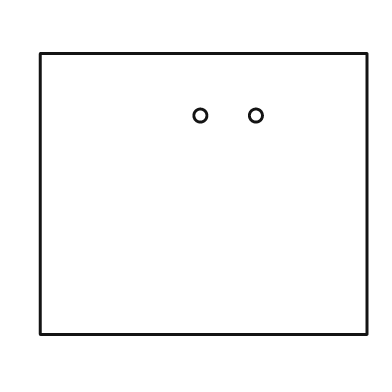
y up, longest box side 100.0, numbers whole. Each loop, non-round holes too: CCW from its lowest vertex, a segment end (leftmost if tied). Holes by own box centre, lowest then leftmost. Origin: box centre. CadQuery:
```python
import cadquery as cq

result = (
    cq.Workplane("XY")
    .moveTo(-50.0, -43.0)
    .lineTo(50.0, -43.0)
    .lineTo(50.0, 43.0)
    .lineTo(-50.0, 43.0)
    .close()
    .moveTo(-1.0, 24.0)
    .circle(2.0)
    .moveTo(16.0, 24.0)
    .circle(2.0)
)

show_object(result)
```